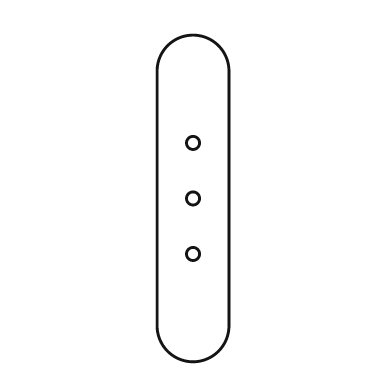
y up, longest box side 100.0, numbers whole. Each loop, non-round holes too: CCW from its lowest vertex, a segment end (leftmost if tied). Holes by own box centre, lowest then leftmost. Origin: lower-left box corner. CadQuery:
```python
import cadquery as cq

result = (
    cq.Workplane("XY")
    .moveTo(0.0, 11.0)
    .threePointArc((11.0, 0.0), (22.0, 11.0))
    .lineTo(22.0, 89.0)
    .threePointArc((11.0, 100.0), (0.0, 89.0))
    .close()
    .moveTo(11.0, 33.0)
    .circle(2.0)
    .moveTo(11.0, 50.0)
    .circle(2.0)
    .moveTo(11.0, 67.0)
    .circle(2.0)
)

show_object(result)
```